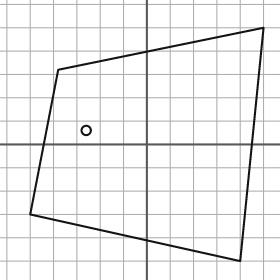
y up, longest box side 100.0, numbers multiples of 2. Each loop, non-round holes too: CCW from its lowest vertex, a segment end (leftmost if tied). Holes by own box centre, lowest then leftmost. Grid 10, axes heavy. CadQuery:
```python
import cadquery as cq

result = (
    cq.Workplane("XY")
    .moveTo(40.0, -50.0)
    .lineTo(50.0, 50.0)
    .lineTo(-38.0, 32.0)
    .lineTo(-50.0, -30.0)
    .close()
    .moveTo(-26.0, 6.0)
    .circle(2.0)
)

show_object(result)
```